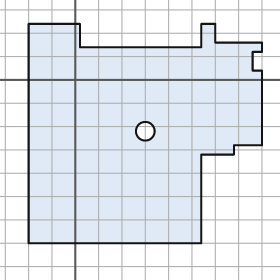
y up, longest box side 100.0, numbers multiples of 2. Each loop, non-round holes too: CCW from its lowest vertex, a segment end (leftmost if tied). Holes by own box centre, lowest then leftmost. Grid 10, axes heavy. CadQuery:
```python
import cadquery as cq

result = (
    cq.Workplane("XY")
    .moveTo(-20.0, -70.0)
    .lineTo(54.0, -70.0)
    .lineTo(54.0, -32.0)
    .lineTo(68.0, -32.0)
    .lineTo(68.0, -28.0)
    .lineTo(80.0, -28.0)
    .lineTo(80.0, 4.0)
    .lineTo(76.0, 4.0)
    .lineTo(76.0, 12.0)
    .lineTo(80.0, 12.0)
    .lineTo(80.0, 16.0)
    .lineTo(60.0, 16.0)
    .lineTo(60.0, 24.0)
    .lineTo(54.0, 24.0)
    .lineTo(54.0, 14.0)
    .lineTo(2.0, 14.0)
    .lineTo(2.0, 24.0)
    .lineTo(-20.0, 24.0)
    .close()
    .moveTo(30.0, -22.0)
    .circle(4.0)
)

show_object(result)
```